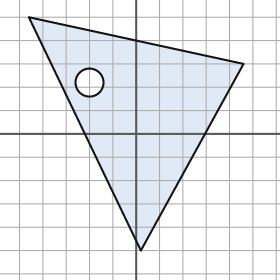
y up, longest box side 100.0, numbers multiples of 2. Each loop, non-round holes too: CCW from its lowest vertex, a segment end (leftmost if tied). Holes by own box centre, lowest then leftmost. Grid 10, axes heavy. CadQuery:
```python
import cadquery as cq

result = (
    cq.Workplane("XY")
    .moveTo(2.0, -50.0)
    .lineTo(46.0, 30.0)
    .lineTo(-46.0, 50.0)
    .close()
    .moveTo(-20.0, 22.0)
    .circle(6.0)
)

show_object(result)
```